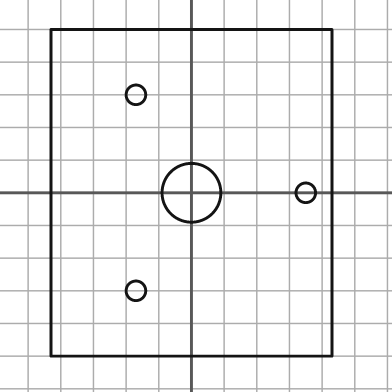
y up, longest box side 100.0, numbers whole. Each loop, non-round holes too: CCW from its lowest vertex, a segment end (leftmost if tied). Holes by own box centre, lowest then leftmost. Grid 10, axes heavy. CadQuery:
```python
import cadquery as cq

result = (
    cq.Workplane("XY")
    .moveTo(-43.0, -50.0)
    .lineTo(43.0, -50.0)
    .lineTo(43.0, 50.0)
    .lineTo(-43.0, 50.0)
    .close()
    .moveTo(-17.0, -30.0)
    .circle(3.0)
    .moveTo(0.0, 0.0)
    .circle(9.0)
    .moveTo(35.0, 0.0)
    .circle(3.0)
    .moveTo(-17.0, 30.0)
    .circle(3.0)
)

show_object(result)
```